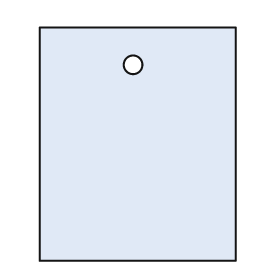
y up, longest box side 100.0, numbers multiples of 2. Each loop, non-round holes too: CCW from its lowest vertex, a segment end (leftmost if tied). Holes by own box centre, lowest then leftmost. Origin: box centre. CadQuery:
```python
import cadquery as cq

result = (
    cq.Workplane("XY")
    .moveTo(-42.0, -50.0)
    .lineTo(42.0, -50.0)
    .lineTo(42.0, 50.0)
    .lineTo(-42.0, 50.0)
    .close()
    .moveTo(-2.0, 34.0)
    .circle(4.0)
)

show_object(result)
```